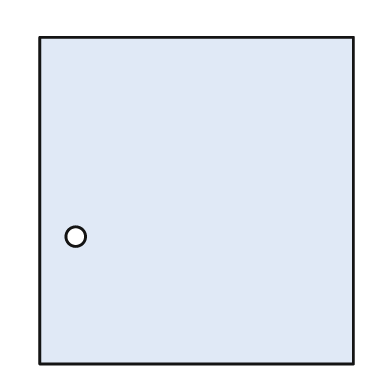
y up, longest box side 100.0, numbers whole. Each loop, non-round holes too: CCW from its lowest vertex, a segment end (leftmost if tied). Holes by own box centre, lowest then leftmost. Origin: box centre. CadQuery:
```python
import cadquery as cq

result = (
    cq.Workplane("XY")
    .moveTo(-48.0, -50.0)
    .lineTo(48.0, -50.0)
    .lineTo(48.0, 50.0)
    .lineTo(-48.0, 50.0)
    .close()
    .moveTo(-37.0, -11.0)
    .circle(3.0)
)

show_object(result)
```